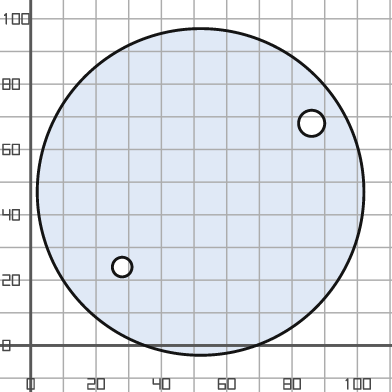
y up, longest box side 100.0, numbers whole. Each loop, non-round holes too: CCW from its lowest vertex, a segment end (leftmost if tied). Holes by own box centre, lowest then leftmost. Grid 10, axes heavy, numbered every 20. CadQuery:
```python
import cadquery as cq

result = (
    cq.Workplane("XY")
    .moveTo(52.0, 47.0)
    .circle(50.0)
    .moveTo(28.0, 24.0)
    .circle(3.0)
    .moveTo(86.0, 68.0)
    .circle(4.0)
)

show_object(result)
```